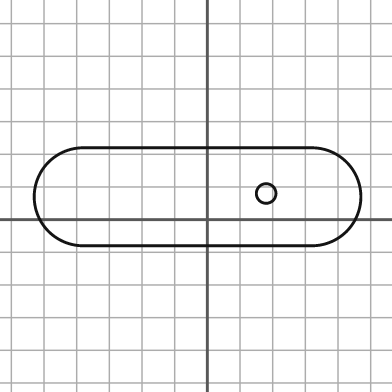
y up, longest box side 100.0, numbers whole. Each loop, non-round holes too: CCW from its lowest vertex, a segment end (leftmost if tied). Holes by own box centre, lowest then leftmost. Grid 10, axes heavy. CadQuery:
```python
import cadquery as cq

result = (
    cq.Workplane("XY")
    .moveTo(-38.0, -8.0)
    .lineTo(32.0, -8.0)
    .threePointArc((47.0, 7.0), (32.0, 22.0))
    .lineTo(-38.0, 22.0)
    .threePointArc((-53.0, 7.0), (-38.0, -8.0))
    .close()
    .moveTo(18.0, 8.0)
    .circle(3.0)
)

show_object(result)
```